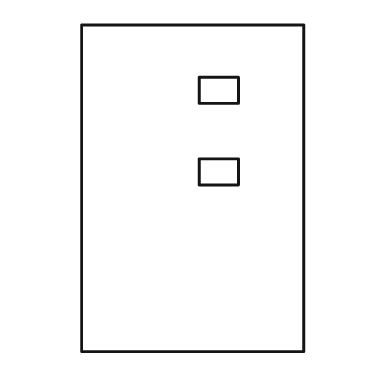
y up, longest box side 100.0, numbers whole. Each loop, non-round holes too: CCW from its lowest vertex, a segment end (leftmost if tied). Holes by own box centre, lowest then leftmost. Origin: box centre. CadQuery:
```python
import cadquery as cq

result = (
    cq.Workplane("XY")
    .moveTo(-34.0, -50.0)
    .lineTo(34.0, -50.0)
    .lineTo(34.0, 50.0)
    .lineTo(-34.0, 50.0)
    .close()
    .moveTo(2.0, 1.0)
    .lineTo(14.0, 1.0)
    .lineTo(14.0, 9.0)
    .lineTo(2.0, 9.0)
    .close()
    .moveTo(2.0, 26.0)
    .lineTo(14.0, 26.0)
    .lineTo(14.0, 34.0)
    .lineTo(2.0, 34.0)
    .close()
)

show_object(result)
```